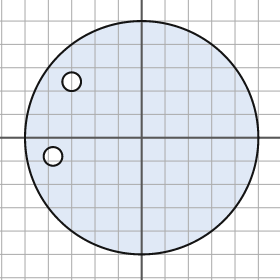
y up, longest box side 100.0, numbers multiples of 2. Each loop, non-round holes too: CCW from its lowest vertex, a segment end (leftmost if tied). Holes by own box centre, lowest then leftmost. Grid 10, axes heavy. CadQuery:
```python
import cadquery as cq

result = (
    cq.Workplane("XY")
    .moveTo(0.0, 0.0)
    .circle(50.0)
    .moveTo(-38.0, -8.0)
    .circle(4.0)
    .moveTo(-30.0, 24.0)
    .circle(4.0)
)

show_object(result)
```